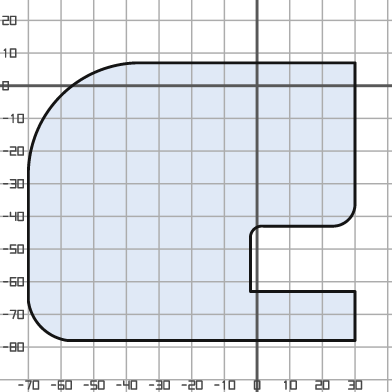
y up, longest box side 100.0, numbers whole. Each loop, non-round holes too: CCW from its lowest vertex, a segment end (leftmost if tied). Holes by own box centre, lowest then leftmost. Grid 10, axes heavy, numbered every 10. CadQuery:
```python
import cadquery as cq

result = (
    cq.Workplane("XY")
    .moveTo(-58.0, -78.0)
    .lineTo(30.0, -78.0)
    .lineTo(30.0, -63.0)
    .lineTo(-2.0, -63.0)
    .lineTo(-2.0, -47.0)
    .threePointArc((-1.0, -44.0), (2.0, -43.0))
    .lineTo(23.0, -43.0)
    .threePointArc((28.0, -41.0), (30.0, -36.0))
    .lineTo(30.0, 7.0)
    .lineTo(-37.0, 7.0)
    .threePointArc((-60.0, -3.0), (-70.0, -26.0))
    .lineTo(-70.0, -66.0)
    .threePointArc((-66.0, -74.0), (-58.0, -78.0))
    .close()
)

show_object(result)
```